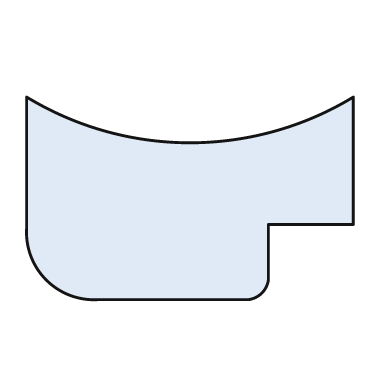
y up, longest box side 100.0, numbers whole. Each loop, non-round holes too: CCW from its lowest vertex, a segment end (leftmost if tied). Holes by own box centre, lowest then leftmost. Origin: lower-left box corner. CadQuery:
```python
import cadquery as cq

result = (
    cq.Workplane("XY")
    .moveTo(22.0, 0.0)
    .lineTo(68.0, 0.0)
    .threePointArc((72.0, 2.0), (74.0, 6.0))
    .lineTo(74.0, 23.0)
    .lineTo(100.0, 23.0)
    .lineTo(100.0, 62.0)
    .threePointArc((50.0, 48.0), (0.0, 62.0))
    .lineTo(0.0, 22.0)
    .threePointArc((6.0, 6.0), (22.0, 0.0))
    .close()
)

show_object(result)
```